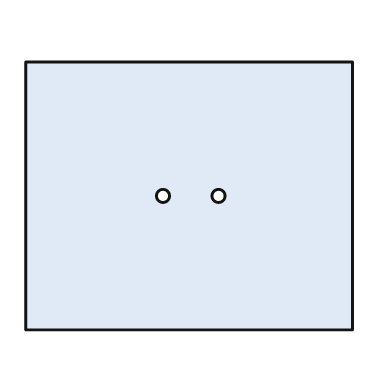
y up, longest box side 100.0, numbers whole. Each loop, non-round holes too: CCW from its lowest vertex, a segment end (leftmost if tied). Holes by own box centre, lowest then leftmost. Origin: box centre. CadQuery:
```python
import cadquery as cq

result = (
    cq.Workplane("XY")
    .moveTo(-50.0, -41.0)
    .lineTo(50.0, -41.0)
    .lineTo(50.0, 41.0)
    .lineTo(-50.0, 41.0)
    .close()
    .moveTo(-8.0, 0.0)
    .circle(2.0)
    .moveTo(9.0, 0.0)
    .circle(2.0)
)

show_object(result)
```